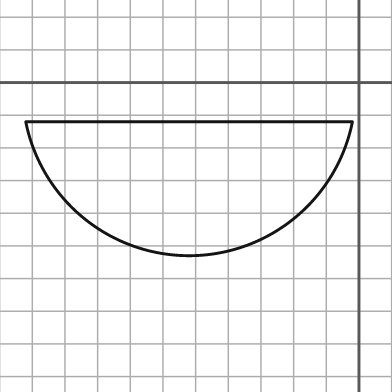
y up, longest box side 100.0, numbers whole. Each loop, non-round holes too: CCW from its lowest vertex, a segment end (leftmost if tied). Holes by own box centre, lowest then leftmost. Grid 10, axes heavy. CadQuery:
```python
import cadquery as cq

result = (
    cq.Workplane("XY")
    .moveTo(-102.0, -12.0)
    .threePointArc((-52.0, -53.0), (-2.0, -12.0))
    .close()
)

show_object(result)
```